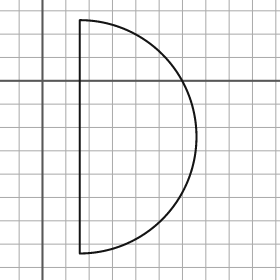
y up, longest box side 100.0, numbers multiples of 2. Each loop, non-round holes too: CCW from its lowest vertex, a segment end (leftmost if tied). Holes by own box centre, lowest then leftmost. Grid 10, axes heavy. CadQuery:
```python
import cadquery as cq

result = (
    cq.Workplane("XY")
    .moveTo(16.0, -74.0)
    .threePointArc((66.0, -24.0), (16.0, 26.0))
    .close()
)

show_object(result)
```